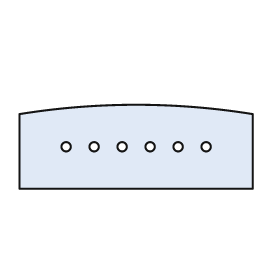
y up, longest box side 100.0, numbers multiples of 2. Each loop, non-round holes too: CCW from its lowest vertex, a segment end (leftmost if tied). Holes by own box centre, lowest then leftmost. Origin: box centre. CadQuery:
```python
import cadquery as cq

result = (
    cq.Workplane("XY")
    .moveTo(-50.0, -18.0)
    .lineTo(50.0, -18.0)
    .lineTo(50.0, 14.0)
    .threePointArc((0.0, 18.0), (-50.0, 14.0))
    .close()
    .moveTo(-30.0, 0.0)
    .circle(2.0)
    .moveTo(-18.0, 0.0)
    .circle(2.0)
    .moveTo(-6.0, 0.0)
    .circle(2.0)
    .moveTo(6.0, 0.0)
    .circle(2.0)
    .moveTo(18.0, 0.0)
    .circle(2.0)
    .moveTo(30.0, 0.0)
    .circle(2.0)
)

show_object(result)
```